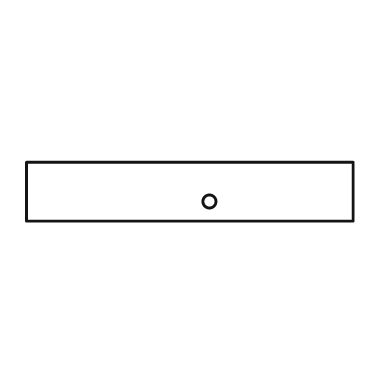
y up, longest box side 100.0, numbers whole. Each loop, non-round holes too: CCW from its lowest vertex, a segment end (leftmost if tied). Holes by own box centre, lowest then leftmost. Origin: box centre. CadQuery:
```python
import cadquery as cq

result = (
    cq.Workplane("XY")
    .moveTo(-50.0, -9.0)
    .lineTo(50.0, -9.0)
    .lineTo(50.0, 9.0)
    .lineTo(-50.0, 9.0)
    .close()
    .moveTo(6.0, -3.0)
    .circle(2.0)
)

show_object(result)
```